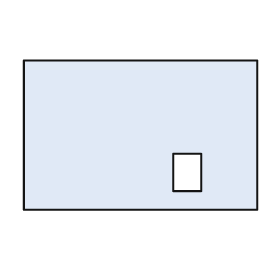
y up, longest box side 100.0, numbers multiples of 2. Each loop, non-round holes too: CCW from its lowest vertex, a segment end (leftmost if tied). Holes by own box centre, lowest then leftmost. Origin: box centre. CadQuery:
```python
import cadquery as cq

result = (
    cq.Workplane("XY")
    .moveTo(-50.0, -32.0)
    .lineTo(50.0, -32.0)
    .lineTo(50.0, 32.0)
    .lineTo(-50.0, 32.0)
    .close()
    .moveTo(14.0, -24.0)
    .lineTo(26.0, -24.0)
    .lineTo(26.0, -8.0)
    .lineTo(14.0, -8.0)
    .close()
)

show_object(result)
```